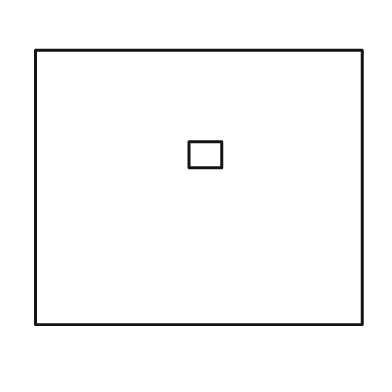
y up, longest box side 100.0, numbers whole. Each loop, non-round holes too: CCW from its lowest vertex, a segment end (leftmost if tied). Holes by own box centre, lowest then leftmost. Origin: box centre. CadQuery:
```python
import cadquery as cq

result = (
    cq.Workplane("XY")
    .moveTo(-50.0, -42.0)
    .lineTo(50.0, -42.0)
    .lineTo(50.0, 42.0)
    .lineTo(-50.0, 42.0)
    .close()
    .moveTo(-3.0, 6.0)
    .lineTo(7.0, 6.0)
    .lineTo(7.0, 14.0)
    .lineTo(-3.0, 14.0)
    .close()
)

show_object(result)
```